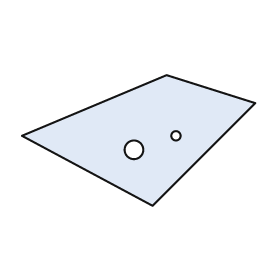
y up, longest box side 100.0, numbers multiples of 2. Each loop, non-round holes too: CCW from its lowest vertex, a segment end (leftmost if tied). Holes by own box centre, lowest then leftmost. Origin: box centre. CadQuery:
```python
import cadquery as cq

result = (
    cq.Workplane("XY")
    .moveTo(6.0, -28.0)
    .lineTo(50.0, 16.0)
    .lineTo(12.0, 28.0)
    .lineTo(-50.0, 2.0)
    .close()
    .moveTo(-2.0, -4.0)
    .circle(4.0)
    .moveTo(16.0, 2.0)
    .circle(2.0)
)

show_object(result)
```